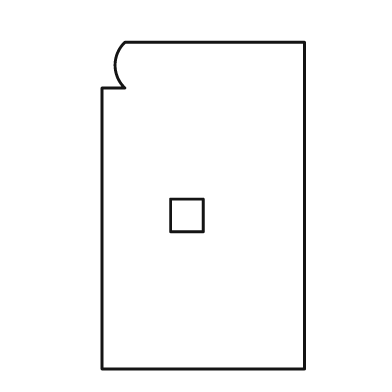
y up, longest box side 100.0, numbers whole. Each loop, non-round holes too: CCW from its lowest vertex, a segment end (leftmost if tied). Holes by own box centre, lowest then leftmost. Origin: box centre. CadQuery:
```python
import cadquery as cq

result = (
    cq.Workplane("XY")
    .moveTo(-31.0, -50.0)
    .lineTo(31.0, -50.0)
    .lineTo(31.0, 50.0)
    .lineTo(-24.0, 50.0)
    .threePointArc((-27.0, 43.0), (-24.0, 36.0))
    .lineTo(-31.0, 36.0)
    .close()
    .moveTo(-10.0, -8.0)
    .lineTo(0.0, -8.0)
    .lineTo(0.0, 2.0)
    .lineTo(-10.0, 2.0)
    .close()
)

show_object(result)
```